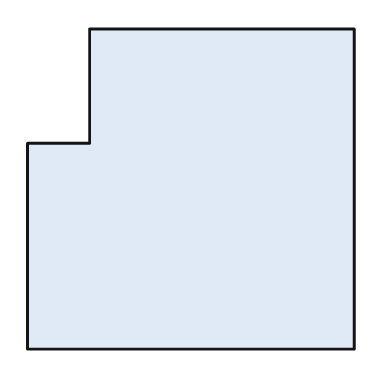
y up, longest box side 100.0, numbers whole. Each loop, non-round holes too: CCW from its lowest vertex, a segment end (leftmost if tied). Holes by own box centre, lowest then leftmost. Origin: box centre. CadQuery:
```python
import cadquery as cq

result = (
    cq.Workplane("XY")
    .moveTo(-50.0, -49.0)
    .lineTo(50.0, -49.0)
    .lineTo(50.0, 49.0)
    .lineTo(-31.0, 49.0)
    .lineTo(-31.0, 14.0)
    .lineTo(-50.0, 14.0)
    .close()
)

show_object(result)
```